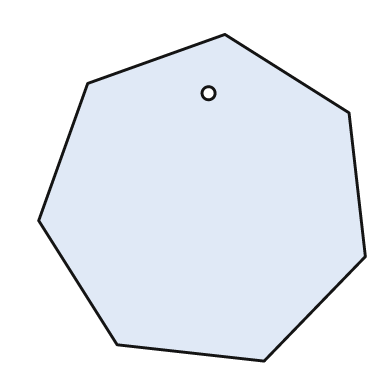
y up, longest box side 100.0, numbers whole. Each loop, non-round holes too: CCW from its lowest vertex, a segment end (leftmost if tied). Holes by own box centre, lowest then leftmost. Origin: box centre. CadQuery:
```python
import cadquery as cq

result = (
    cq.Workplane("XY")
    .moveTo(19.0, -50.0)
    .lineTo(50.0, -18.0)
    .lineTo(45.0, 26.0)
    .lineTo(7.0, 50.0)
    .lineTo(-35.0, 35.0)
    .lineTo(-50.0, -7.0)
    .lineTo(-26.0, -45.0)
    .close()
    .moveTo(2.0, 32.0)
    .circle(2.0)
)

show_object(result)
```